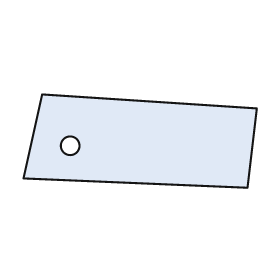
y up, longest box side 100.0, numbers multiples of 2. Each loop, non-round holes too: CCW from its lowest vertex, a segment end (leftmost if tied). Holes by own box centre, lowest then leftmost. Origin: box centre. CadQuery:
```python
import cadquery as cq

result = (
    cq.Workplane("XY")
    .moveTo(46.0, -20.0)
    .lineTo(50.0, 14.0)
    .lineTo(-42.0, 20.0)
    .lineTo(-50.0, -16.0)
    .close()
    .moveTo(-30.0, -2.0)
    .circle(4.0)
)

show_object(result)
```